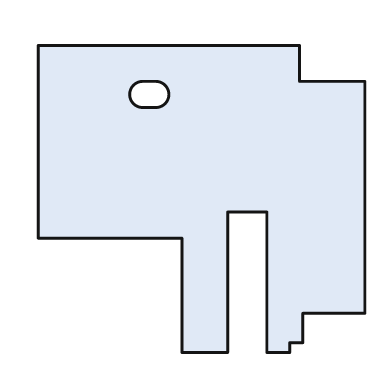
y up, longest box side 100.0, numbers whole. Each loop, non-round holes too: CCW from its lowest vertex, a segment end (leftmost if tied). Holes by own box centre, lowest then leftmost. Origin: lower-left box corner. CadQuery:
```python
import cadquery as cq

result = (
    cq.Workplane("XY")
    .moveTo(44.0, 0.0)
    .lineTo(58.0, 0.0)
    .lineTo(58.0, 43.0)
    .lineTo(70.0, 43.0)
    .lineTo(70.0, 0.0)
    .lineTo(77.0, 0.0)
    .lineTo(77.0, 3.0)
    .lineTo(81.0, 3.0)
    .lineTo(81.0, 12.0)
    .lineTo(100.0, 12.0)
    .lineTo(100.0, 83.0)
    .lineTo(80.0, 83.0)
    .lineTo(80.0, 94.0)
    .lineTo(0.0, 94.0)
    .lineTo(0.0, 35.0)
    .lineTo(44.0, 35.0)
    .close()
    .moveTo(32.0, 75.0)
    .lineTo(36.0, 75.0)
    .threePointArc((40.0, 79.0), (36.0, 83.0))
    .lineTo(32.0, 83.0)
    .threePointArc((28.0, 79.0), (32.0, 75.0))
    .close()
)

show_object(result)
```